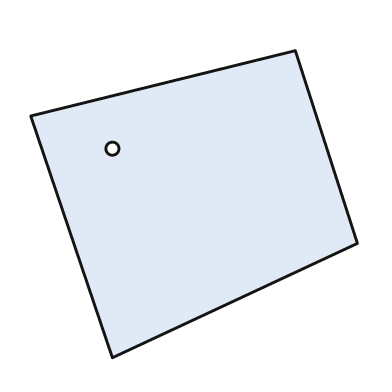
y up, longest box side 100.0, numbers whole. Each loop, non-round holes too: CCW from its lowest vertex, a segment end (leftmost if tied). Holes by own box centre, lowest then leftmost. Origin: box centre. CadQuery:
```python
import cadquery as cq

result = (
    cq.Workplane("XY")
    .moveTo(-25.0, -47.0)
    .lineTo(50.0, -12.0)
    .lineTo(31.0, 47.0)
    .lineTo(-50.0, 27.0)
    .close()
    .moveTo(-25.0, 17.0)
    .circle(2.0)
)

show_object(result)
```